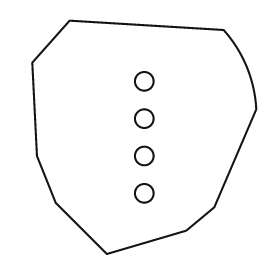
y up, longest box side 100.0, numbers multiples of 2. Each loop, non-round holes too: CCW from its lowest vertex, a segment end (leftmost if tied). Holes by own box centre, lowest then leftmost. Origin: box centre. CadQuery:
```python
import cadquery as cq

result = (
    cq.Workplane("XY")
    .moveTo(-16.0, -50.0)
    .lineTo(18.0, -40.0)
    .lineTo(30.0, -30.0)
    .lineTo(48.0, 12.0)
    .threePointArc((44.0, 30.0), (34.0, 46.0))
    .lineTo(-32.0, 50.0)
    .lineTo(-48.0, 32.0)
    .lineTo(-46.0, -8.0)
    .lineTo(-38.0, -28.0)
    .close()
    .moveTo(0.0, -24.0)
    .circle(4.0)
    .moveTo(0.0, -8.0)
    .circle(4.0)
    .moveTo(0.0, 8.0)
    .circle(4.0)
    .moveTo(0.0, 24.0)
    .circle(4.0)
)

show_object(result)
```